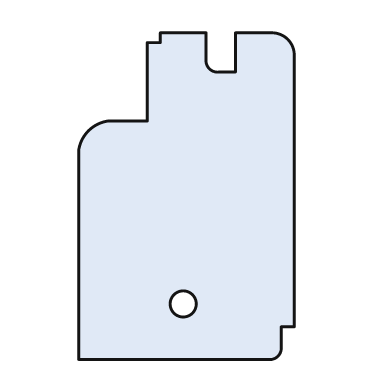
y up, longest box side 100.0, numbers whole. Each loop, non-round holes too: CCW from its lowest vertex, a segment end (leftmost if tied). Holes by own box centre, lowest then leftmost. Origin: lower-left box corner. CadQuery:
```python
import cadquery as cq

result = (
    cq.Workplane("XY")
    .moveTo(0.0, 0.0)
    .lineTo(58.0, 0.0)
    .threePointArc((61.0, 1.0), (62.0, 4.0))
    .lineTo(62.0, 10.0)
    .lineTo(66.0, 10.0)
    .lineTo(66.0, 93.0)
    .threePointArc((64.0, 98.0), (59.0, 100.0))
    .lineTo(48.0, 100.0)
    .lineTo(48.0, 88.0)
    .lineTo(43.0, 88.0)
    .threePointArc((40.0, 89.0), (39.0, 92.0))
    .lineTo(39.0, 100.0)
    .lineTo(25.0, 100.0)
    .lineTo(25.0, 97.0)
    .lineTo(21.0, 97.0)
    .lineTo(21.0, 73.0)
    .lineTo(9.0, 73.0)
    .threePointArc((3.0, 70.0), (0.0, 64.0))
    .close()
    .moveTo(32.0, 17.0)
    .circle(4.0)
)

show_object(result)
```